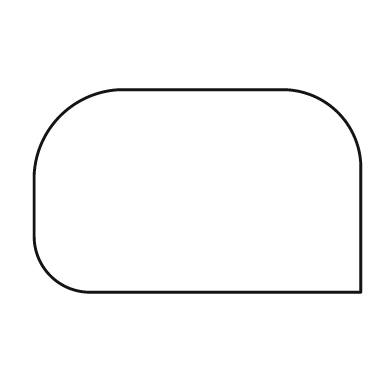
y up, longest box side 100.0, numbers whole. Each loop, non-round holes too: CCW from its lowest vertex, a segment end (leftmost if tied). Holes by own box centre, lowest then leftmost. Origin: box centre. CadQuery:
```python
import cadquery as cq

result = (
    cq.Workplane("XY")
    .moveTo(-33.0, -31.0)
    .lineTo(50.0, -31.0)
    .lineTo(50.0, 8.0)
    .threePointArc((43.0, 24.0), (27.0, 31.0))
    .lineTo(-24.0, 31.0)
    .threePointArc((-42.0, 23.0), (-50.0, 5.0))
    .lineTo(-50.0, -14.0)
    .threePointArc((-45.0, -26.0), (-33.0, -31.0))
    .close()
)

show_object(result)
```